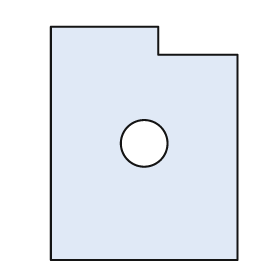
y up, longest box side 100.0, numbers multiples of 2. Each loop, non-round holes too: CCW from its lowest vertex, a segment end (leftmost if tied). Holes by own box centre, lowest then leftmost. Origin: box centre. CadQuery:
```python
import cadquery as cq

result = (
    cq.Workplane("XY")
    .moveTo(-40.0, -50.0)
    .lineTo(40.0, -50.0)
    .lineTo(40.0, 38.0)
    .lineTo(6.0, 38.0)
    .lineTo(6.0, 50.0)
    .lineTo(-40.0, 50.0)
    .close()
    .moveTo(0.0, 0.0)
    .circle(10.0)
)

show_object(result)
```